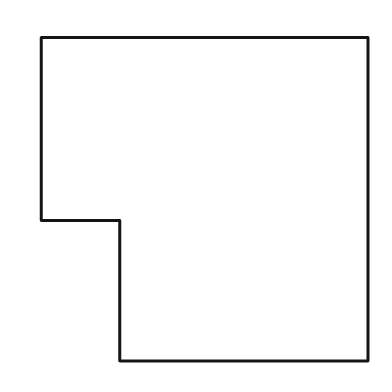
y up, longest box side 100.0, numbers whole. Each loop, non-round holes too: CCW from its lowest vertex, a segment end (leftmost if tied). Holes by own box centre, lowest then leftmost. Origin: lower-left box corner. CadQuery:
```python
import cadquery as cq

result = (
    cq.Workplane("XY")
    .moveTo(24.0, 0.0)
    .lineTo(100.0, 0.0)
    .lineTo(100.0, 99.0)
    .lineTo(0.0, 99.0)
    .lineTo(0.0, 43.0)
    .lineTo(24.0, 43.0)
    .close()
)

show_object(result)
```